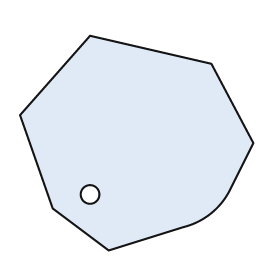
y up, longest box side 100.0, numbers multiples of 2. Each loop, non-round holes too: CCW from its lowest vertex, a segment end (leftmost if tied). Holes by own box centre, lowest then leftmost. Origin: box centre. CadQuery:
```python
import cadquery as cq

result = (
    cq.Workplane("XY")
    .moveTo(-12.0, -46.0)
    .lineTo(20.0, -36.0)
    .threePointArc((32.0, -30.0), (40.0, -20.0))
    .lineTo(50.0, 0.0)
    .lineTo(32.0, 34.0)
    .lineTo(-20.0, 46.0)
    .lineTo(-50.0, 12.0)
    .lineTo(-36.0, -28.0)
    .close()
    .moveTo(-20.0, -22.0)
    .circle(4.0)
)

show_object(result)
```